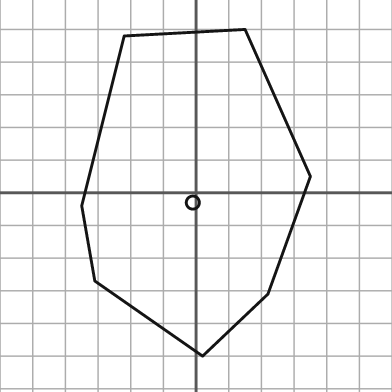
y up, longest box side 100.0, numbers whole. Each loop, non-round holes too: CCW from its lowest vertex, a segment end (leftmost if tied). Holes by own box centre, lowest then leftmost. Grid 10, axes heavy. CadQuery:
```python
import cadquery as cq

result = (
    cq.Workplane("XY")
    .moveTo(2.0, -50.0)
    .lineTo(22.0, -31.0)
    .lineTo(35.0, 5.0)
    .lineTo(15.0, 50.0)
    .lineTo(-22.0, 48.0)
    .lineTo(-35.0, -4.0)
    .lineTo(-31.0, -27.0)
    .close()
    .moveTo(-1.0, -3.0)
    .circle(2.0)
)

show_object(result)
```